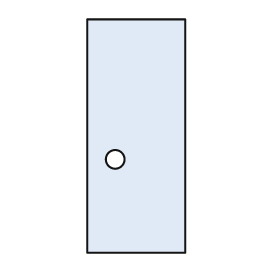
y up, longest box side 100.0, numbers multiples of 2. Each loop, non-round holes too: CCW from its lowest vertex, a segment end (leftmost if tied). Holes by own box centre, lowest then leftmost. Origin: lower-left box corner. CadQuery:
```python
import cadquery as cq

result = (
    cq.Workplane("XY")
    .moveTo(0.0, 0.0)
    .lineTo(42.0, 0.0)
    .lineTo(42.0, 100.0)
    .lineTo(0.0, 100.0)
    .close()
    .moveTo(12.0, 40.0)
    .circle(4.0)
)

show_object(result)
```